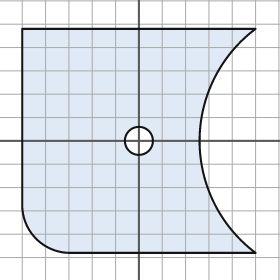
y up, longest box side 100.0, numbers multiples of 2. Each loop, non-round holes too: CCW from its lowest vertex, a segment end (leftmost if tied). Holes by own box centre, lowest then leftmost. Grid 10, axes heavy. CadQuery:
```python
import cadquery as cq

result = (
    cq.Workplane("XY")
    .moveTo(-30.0, -48.0)
    .lineTo(50.0, -48.0)
    .threePointArc((26.0, 0.0), (50.0, 48.0))
    .lineTo(-50.0, 48.0)
    .lineTo(-50.0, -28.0)
    .threePointArc((-44.0, -42.0), (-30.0, -48.0))
    .close()
    .moveTo(0.0, 0.0)
    .circle(6.0)
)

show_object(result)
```